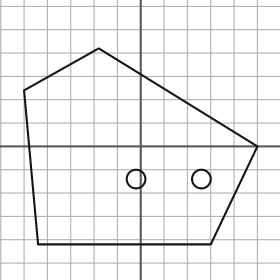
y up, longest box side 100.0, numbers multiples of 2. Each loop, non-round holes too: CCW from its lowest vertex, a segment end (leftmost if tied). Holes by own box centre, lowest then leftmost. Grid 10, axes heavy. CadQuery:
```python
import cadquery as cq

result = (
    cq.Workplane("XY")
    .moveTo(-44.0, -42.0)
    .lineTo(30.0, -42.0)
    .lineTo(50.0, 0.0)
    .lineTo(-18.0, 42.0)
    .lineTo(-50.0, 24.0)
    .close()
    .moveTo(-2.0, -14.0)
    .circle(4.0)
    .moveTo(26.0, -14.0)
    .circle(4.0)
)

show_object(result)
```